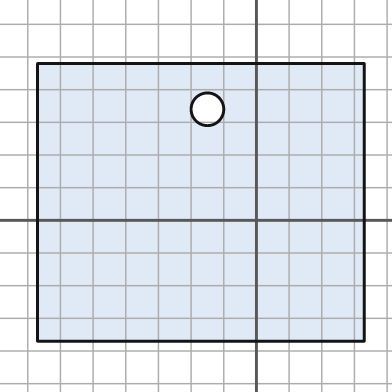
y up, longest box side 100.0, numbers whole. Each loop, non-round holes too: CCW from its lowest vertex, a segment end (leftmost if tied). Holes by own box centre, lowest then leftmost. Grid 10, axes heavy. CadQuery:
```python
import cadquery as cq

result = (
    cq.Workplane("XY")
    .moveTo(-67.0, -37.0)
    .lineTo(33.0, -37.0)
    .lineTo(33.0, 48.0)
    .lineTo(-67.0, 48.0)
    .close()
    .moveTo(-15.0, 34.0)
    .circle(5.0)
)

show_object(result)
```